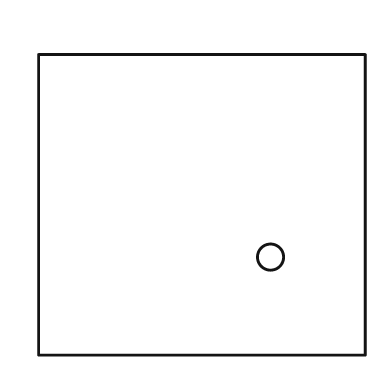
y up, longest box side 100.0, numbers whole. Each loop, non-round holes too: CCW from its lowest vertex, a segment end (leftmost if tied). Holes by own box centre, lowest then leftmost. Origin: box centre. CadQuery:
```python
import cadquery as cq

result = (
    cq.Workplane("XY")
    .moveTo(-50.0, -46.0)
    .lineTo(50.0, -46.0)
    .lineTo(50.0, 46.0)
    .lineTo(-50.0, 46.0)
    .close()
    .moveTo(21.0, -16.0)
    .circle(4.0)
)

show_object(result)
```